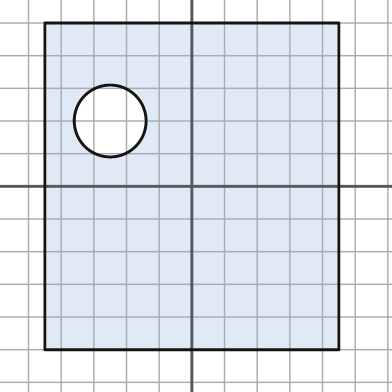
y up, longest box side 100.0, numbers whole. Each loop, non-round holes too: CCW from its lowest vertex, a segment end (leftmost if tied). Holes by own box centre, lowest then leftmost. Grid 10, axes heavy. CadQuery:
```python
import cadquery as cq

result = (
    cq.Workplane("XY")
    .moveTo(-45.0, -50.0)
    .lineTo(45.0, -50.0)
    .lineTo(45.0, 50.0)
    .lineTo(-45.0, 50.0)
    .close()
    .moveTo(-25.0, 20.0)
    .circle(11.0)
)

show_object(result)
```